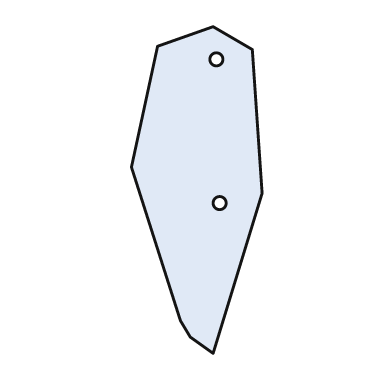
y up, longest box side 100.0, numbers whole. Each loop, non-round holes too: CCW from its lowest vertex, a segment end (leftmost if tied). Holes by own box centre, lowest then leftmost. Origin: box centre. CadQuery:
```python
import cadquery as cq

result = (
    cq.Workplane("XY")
    .moveTo(5.0, -50.0)
    .lineTo(20.0, -1.0)
    .lineTo(17.0, 43.0)
    .lineTo(5.0, 50.0)
    .lineTo(-12.0, 44.0)
    .lineTo(-20.0, 7.0)
    .lineTo(-5.0, -40.0)
    .lineTo(-2.0, -45.0)
    .close()
    .moveTo(7.0, -4.0)
    .circle(2.0)
    .moveTo(6.0, 40.0)
    .circle(2.0)
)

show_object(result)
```